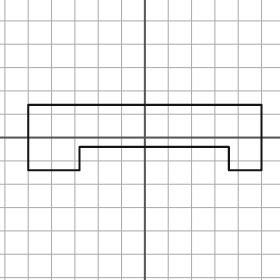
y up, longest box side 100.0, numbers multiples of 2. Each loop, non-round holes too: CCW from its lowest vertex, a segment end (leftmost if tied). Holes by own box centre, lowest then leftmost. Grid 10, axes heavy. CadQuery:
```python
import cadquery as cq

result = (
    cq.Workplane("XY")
    .moveTo(-50.0, -14.0)
    .lineTo(-28.0, -14.0)
    .lineTo(-28.0, -4.0)
    .lineTo(36.0, -4.0)
    .lineTo(36.0, -14.0)
    .lineTo(50.0, -14.0)
    .lineTo(50.0, 14.0)
    .lineTo(-50.0, 14.0)
    .close()
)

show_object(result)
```